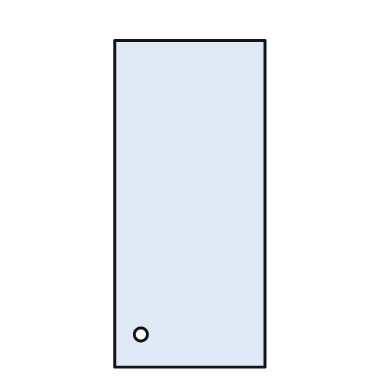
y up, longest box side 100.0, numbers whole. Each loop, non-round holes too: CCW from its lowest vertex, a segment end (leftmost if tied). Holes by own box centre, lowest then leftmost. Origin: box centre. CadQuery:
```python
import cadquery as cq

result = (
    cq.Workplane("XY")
    .moveTo(-23.0, -50.0)
    .lineTo(23.0, -50.0)
    .lineTo(23.0, 50.0)
    .lineTo(-23.0, 50.0)
    .close()
    .moveTo(-15.0, -40.0)
    .circle(2.0)
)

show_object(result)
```